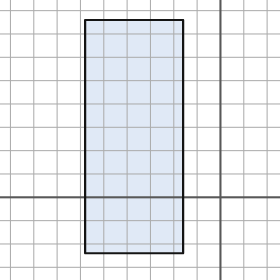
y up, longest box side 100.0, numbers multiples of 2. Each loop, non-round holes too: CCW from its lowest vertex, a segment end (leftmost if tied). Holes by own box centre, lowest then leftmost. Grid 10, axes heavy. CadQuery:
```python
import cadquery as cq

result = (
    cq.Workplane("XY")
    .moveTo(-58.0, -24.0)
    .lineTo(-16.0, -24.0)
    .lineTo(-16.0, 76.0)
    .lineTo(-58.0, 76.0)
    .close()
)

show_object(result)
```